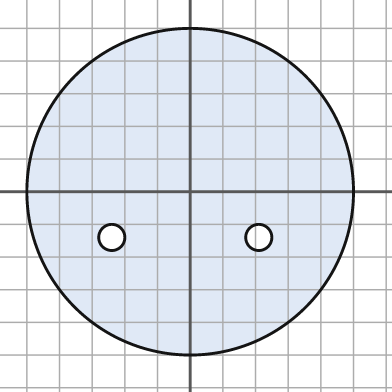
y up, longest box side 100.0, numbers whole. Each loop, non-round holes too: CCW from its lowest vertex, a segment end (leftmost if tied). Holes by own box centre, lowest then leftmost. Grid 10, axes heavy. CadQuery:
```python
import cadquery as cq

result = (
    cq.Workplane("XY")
    .moveTo(0.0, 0.0)
    .circle(50.0)
    .moveTo(-24.0, -14.0)
    .circle(4.0)
    .moveTo(21.0, -14.0)
    .circle(4.0)
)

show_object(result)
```